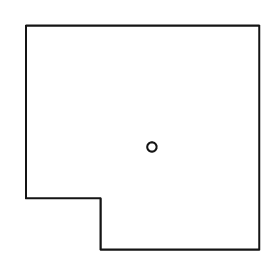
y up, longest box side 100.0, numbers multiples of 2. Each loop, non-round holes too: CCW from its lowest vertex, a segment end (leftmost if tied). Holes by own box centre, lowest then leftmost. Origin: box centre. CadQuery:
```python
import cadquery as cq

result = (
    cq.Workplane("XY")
    .moveTo(-18.0, -48.0)
    .lineTo(50.0, -48.0)
    .lineTo(50.0, 48.0)
    .lineTo(-50.0, 48.0)
    .lineTo(-50.0, -26.0)
    .lineTo(-18.0, -26.0)
    .close()
    .moveTo(4.0, -4.0)
    .circle(2.0)
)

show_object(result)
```